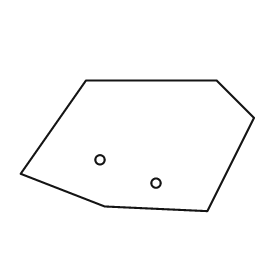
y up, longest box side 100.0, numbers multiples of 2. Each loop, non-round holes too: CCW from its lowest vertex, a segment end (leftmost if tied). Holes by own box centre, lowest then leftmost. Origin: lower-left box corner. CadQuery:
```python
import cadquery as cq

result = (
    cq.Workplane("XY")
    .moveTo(80.0, 0.0)
    .lineTo(100.0, 40.0)
    .lineTo(84.0, 56.0)
    .lineTo(28.0, 56.0)
    .lineTo(0.0, 16.0)
    .lineTo(36.0, 2.0)
    .close()
    .moveTo(58.0, 12.0)
    .circle(2.0)
    .moveTo(34.0, 22.0)
    .circle(2.0)
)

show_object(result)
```